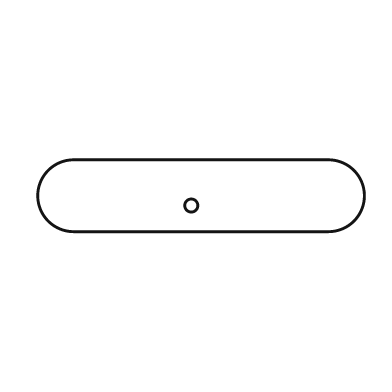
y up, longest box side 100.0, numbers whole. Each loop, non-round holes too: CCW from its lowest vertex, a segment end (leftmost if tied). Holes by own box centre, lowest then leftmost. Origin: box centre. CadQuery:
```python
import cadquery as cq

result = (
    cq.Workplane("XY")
    .moveTo(-39.0, -11.0)
    .lineTo(39.0, -11.0)
    .threePointArc((50.0, 0.0), (39.0, 11.0))
    .lineTo(-39.0, 11.0)
    .threePointArc((-50.0, 0.0), (-39.0, -11.0))
    .close()
    .moveTo(-3.0, -3.0)
    .circle(2.0)
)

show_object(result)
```